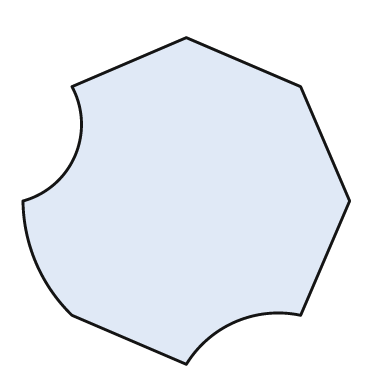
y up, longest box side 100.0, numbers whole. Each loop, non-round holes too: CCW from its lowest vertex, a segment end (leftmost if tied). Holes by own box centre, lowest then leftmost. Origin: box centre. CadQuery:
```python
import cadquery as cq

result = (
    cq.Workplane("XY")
    .moveTo(0.0, -50.0)
    .threePointArc((15.0, -37.0), (35.0, -35.0))
    .lineTo(50.0, 0.0)
    .lineTo(35.0, 35.0)
    .lineTo(0.0, 50.0)
    .lineTo(-35.0, 35.0)
    .threePointArc((-34.0, 14.0), (-50.0, 0.0))
    .threePointArc((-46.0, -19.0), (-35.0, -35.0))
    .close()
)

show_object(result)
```